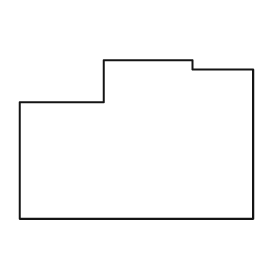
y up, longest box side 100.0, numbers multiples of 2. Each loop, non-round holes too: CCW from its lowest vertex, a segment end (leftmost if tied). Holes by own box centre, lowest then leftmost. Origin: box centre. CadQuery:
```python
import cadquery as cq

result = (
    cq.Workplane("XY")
    .moveTo(-50.0, -34.0)
    .lineTo(50.0, -34.0)
    .lineTo(50.0, 30.0)
    .lineTo(24.0, 30.0)
    .lineTo(24.0, 34.0)
    .lineTo(-14.0, 34.0)
    .lineTo(-14.0, 16.0)
    .lineTo(-50.0, 16.0)
    .close()
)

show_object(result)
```